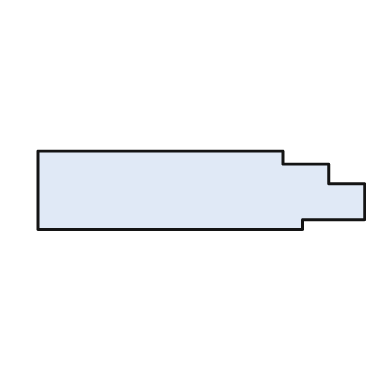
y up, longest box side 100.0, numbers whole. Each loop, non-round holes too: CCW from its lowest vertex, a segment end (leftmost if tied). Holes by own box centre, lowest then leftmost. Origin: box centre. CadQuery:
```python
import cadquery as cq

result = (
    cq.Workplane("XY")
    .moveTo(-50.0, -12.0)
    .lineTo(31.0, -12.0)
    .lineTo(31.0, -9.0)
    .lineTo(50.0, -9.0)
    .lineTo(50.0, 2.0)
    .lineTo(39.0, 2.0)
    .lineTo(39.0, 8.0)
    .lineTo(25.0, 8.0)
    .lineTo(25.0, 12.0)
    .lineTo(-50.0, 12.0)
    .close()
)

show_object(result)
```